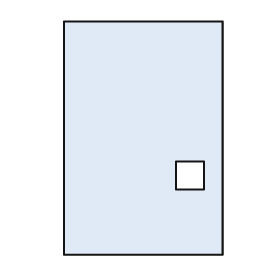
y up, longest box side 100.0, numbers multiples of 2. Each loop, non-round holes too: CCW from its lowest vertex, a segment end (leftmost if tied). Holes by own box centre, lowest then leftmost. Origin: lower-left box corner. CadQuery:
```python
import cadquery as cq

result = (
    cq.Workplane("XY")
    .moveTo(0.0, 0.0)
    .lineTo(68.0, 0.0)
    .lineTo(68.0, 100.0)
    .lineTo(0.0, 100.0)
    .close()
    .moveTo(48.0, 28.0)
    .lineTo(60.0, 28.0)
    .lineTo(60.0, 40.0)
    .lineTo(48.0, 40.0)
    .close()
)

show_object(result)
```